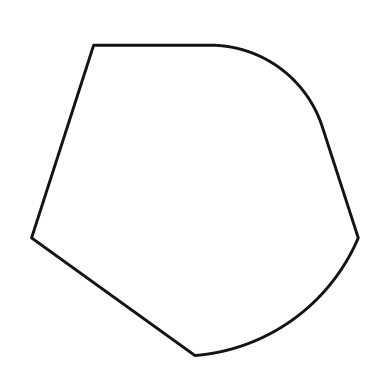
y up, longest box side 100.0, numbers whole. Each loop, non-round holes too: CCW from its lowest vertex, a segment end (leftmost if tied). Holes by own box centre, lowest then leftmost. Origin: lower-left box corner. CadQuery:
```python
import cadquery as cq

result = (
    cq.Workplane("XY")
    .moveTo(50.0, 0.0)
    .threePointArc((80.0, 11.0), (100.0, 36.0))
    .lineTo(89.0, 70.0)
    .threePointArc((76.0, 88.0), (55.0, 95.0))
    .lineTo(19.0, 95.0)
    .lineTo(0.0, 36.0)
    .close()
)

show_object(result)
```